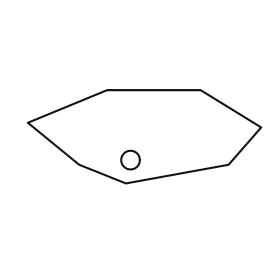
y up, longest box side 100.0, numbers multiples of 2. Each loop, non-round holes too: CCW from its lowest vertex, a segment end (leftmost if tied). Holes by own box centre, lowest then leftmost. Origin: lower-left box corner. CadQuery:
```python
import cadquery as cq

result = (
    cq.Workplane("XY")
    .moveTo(42.0, 0.0)
    .lineTo(86.0, 8.0)
    .lineTo(100.0, 24.0)
    .lineTo(74.0, 40.0)
    .lineTo(34.0, 40.0)
    .lineTo(0.0, 26.0)
    .lineTo(22.0, 8.0)
    .close()
    .moveTo(44.0, 10.0)
    .circle(4.0)
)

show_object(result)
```